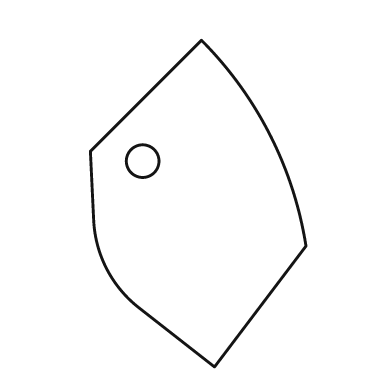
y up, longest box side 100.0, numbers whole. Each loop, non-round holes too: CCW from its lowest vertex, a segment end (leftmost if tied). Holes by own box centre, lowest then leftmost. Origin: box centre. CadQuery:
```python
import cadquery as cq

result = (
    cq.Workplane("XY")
    .moveTo(5.0, -50.0)
    .lineTo(33.0, -13.0)
    .threePointArc((22.0, 21.0), (1.0, 50.0))
    .lineTo(-33.0, 16.0)
    .lineTo(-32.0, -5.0)
    .threePointArc((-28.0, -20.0), (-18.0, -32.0))
    .close()
    .moveTo(-17.0, 13.0)
    .circle(5.0)
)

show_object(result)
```